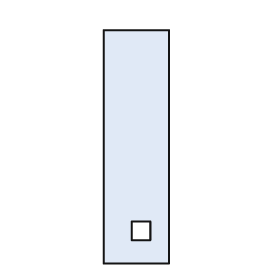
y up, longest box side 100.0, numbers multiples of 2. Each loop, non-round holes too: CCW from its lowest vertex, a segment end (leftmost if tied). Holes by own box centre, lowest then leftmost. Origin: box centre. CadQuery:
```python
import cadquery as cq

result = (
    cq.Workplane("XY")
    .moveTo(-14.0, -50.0)
    .lineTo(14.0, -50.0)
    .lineTo(14.0, 50.0)
    .lineTo(-14.0, 50.0)
    .close()
    .moveTo(-2.0, -40.0)
    .lineTo(6.0, -40.0)
    .lineTo(6.0, -32.0)
    .lineTo(-2.0, -32.0)
    .close()
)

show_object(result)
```